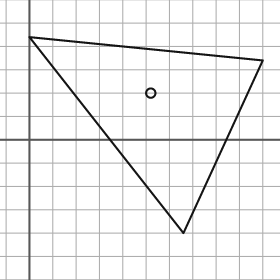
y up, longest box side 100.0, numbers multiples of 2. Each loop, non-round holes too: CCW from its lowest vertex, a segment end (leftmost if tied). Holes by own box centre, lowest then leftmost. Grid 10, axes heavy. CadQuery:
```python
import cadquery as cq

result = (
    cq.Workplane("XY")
    .moveTo(66.0, -40.0)
    .lineTo(100.0, 34.0)
    .lineTo(0.0, 44.0)
    .close()
    .moveTo(52.0, 20.0)
    .circle(2.0)
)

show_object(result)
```